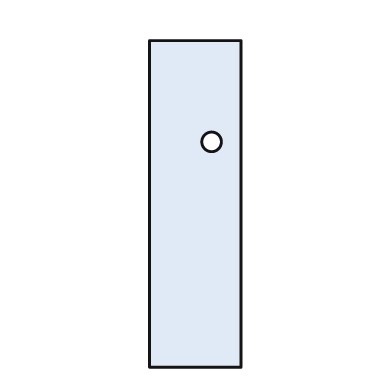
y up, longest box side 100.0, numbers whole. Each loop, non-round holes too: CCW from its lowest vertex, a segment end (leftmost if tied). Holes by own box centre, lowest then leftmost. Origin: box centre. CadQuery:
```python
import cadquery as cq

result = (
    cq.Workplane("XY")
    .moveTo(-14.0, -50.0)
    .lineTo(14.0, -50.0)
    .lineTo(14.0, 50.0)
    .lineTo(-14.0, 50.0)
    .close()
    .moveTo(5.0, 19.0)
    .circle(3.0)
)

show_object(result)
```